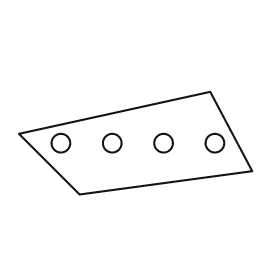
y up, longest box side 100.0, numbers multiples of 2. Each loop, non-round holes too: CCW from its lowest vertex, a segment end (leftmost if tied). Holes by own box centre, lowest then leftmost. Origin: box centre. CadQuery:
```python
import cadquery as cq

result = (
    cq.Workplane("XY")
    .moveTo(-24.0, -22.0)
    .lineTo(50.0, -12.0)
    .lineTo(32.0, 22.0)
    .lineTo(-50.0, 4.0)
    .close()
    .moveTo(-32.0, 0.0)
    .circle(4.0)
    .moveTo(-10.0, 0.0)
    .circle(4.0)
    .moveTo(12.0, 0.0)
    .circle(4.0)
    .moveTo(34.0, 0.0)
    .circle(4.0)
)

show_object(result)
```